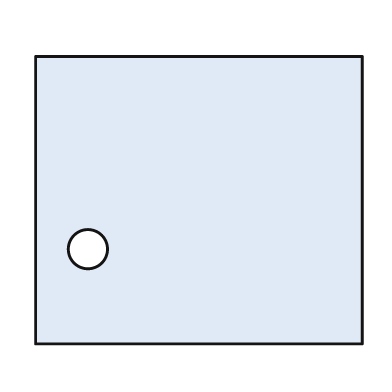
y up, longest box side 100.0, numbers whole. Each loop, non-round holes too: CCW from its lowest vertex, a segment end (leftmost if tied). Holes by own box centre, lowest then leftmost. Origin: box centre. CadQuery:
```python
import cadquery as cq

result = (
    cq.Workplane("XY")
    .moveTo(-50.0, -44.0)
    .lineTo(50.0, -44.0)
    .lineTo(50.0, 44.0)
    .lineTo(-50.0, 44.0)
    .close()
    .moveTo(-34.0, -15.0)
    .circle(6.0)
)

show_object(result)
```